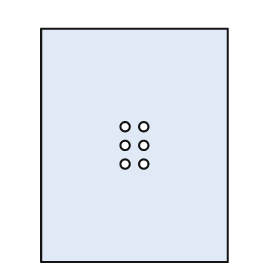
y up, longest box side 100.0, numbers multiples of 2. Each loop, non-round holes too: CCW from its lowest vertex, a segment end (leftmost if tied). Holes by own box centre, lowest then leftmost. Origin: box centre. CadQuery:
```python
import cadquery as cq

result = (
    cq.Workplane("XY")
    .moveTo(-40.0, -50.0)
    .lineTo(40.0, -50.0)
    .lineTo(40.0, 50.0)
    .lineTo(-40.0, 50.0)
    .close()
    .moveTo(-4.0, -8.0)
    .circle(2.0)
    .moveTo(4.0, -8.0)
    .circle(2.0)
    .moveTo(-4.0, 0.0)
    .circle(2.0)
    .moveTo(4.0, 0.0)
    .circle(2.0)
    .moveTo(-4.0, 8.0)
    .circle(2.0)
    .moveTo(4.0, 8.0)
    .circle(2.0)
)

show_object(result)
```